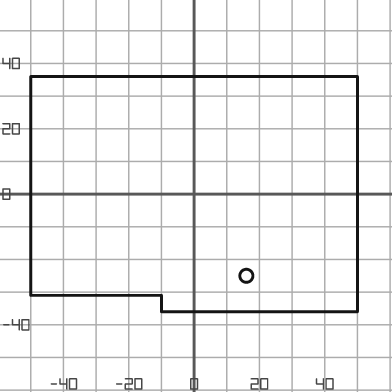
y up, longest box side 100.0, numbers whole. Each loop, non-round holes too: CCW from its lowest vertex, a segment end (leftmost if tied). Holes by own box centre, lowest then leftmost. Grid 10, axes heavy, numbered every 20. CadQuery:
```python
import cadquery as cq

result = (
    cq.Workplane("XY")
    .moveTo(-10.0, -36.0)
    .lineTo(50.0, -36.0)
    .lineTo(50.0, 36.0)
    .lineTo(-50.0, 36.0)
    .lineTo(-50.0, -31.0)
    .lineTo(-10.0, -31.0)
    .close()
    .moveTo(16.0, -25.0)
    .circle(2.0)
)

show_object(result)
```